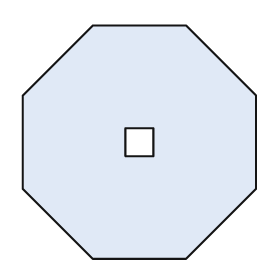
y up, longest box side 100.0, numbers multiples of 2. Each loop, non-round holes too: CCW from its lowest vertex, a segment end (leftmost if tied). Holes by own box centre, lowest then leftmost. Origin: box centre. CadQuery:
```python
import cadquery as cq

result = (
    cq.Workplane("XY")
    .moveTo(-20.0, -50.0)
    .lineTo(20.0, -50.0)
    .lineTo(50.0, -20.0)
    .lineTo(50.0, 20.0)
    .lineTo(20.0, 50.0)
    .lineTo(-20.0, 50.0)
    .lineTo(-50.0, 20.0)
    .lineTo(-50.0, -20.0)
    .close()
    .moveTo(-6.0, -6.0)
    .lineTo(6.0, -6.0)
    .lineTo(6.0, 6.0)
    .lineTo(-6.0, 6.0)
    .close()
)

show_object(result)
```